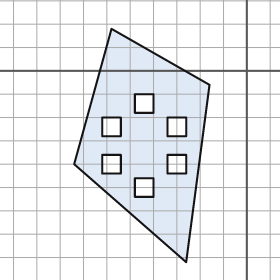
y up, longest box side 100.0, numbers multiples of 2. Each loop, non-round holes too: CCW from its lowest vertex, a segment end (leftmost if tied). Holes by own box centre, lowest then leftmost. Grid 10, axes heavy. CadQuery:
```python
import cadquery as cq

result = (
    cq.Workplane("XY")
    .moveTo(-26.0, -82.0)
    .lineTo(-16.0, -6.0)
    .lineTo(-58.0, 18.0)
    .lineTo(-74.0, -40.0)
    .close()
    .moveTo(-48.0, -54.0)
    .lineTo(-40.0, -54.0)
    .lineTo(-40.0, -46.0)
    .lineTo(-48.0, -46.0)
    .close()
    .moveTo(-62.0, -44.0)
    .lineTo(-54.0, -44.0)
    .lineTo(-54.0, -36.0)
    .lineTo(-62.0, -36.0)
    .close()
    .moveTo(-34.0, -44.0)
    .lineTo(-26.0, -44.0)
    .lineTo(-26.0, -36.0)
    .lineTo(-34.0, -36.0)
    .close()
    .moveTo(-62.0, -28.0)
    .lineTo(-54.0, -28.0)
    .lineTo(-54.0, -20.0)
    .lineTo(-62.0, -20.0)
    .close()
    .moveTo(-34.0, -28.0)
    .lineTo(-26.0, -28.0)
    .lineTo(-26.0, -20.0)
    .lineTo(-34.0, -20.0)
    .close()
    .moveTo(-48.0, -18.0)
    .lineTo(-40.0, -18.0)
    .lineTo(-40.0, -10.0)
    .lineTo(-48.0, -10.0)
    .close()
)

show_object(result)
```